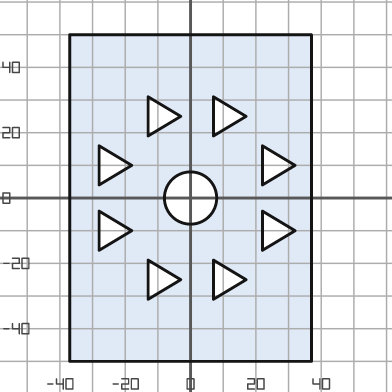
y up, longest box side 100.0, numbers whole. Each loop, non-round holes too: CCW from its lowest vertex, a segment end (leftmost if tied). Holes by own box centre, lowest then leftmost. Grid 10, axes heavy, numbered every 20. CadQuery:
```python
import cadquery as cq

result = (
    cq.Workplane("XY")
    .moveTo(-37.0, -50.0)
    .lineTo(37.0, -50.0)
    .lineTo(37.0, 50.0)
    .lineTo(-37.0, 50.0)
    .close()
    .moveTo(-13.0, -31.0)
    .lineTo(-3.0, -25.0)
    .lineTo(-13.0, -19.0)
    .close()
    .moveTo(7.0, -31.0)
    .lineTo(17.0, -25.0)
    .lineTo(7.0, -19.0)
    .close()
    .moveTo(-28.0, -16.0)
    .lineTo(-18.0, -10.0)
    .lineTo(-28.0, -4.0)
    .close()
    .moveTo(22.0, -16.0)
    .lineTo(32.0, -10.0)
    .lineTo(22.0, -4.0)
    .close()
    .moveTo(0.0, 0.0)
    .circle(8.0)
    .moveTo(-28.0, 4.0)
    .lineTo(-18.0, 10.0)
    .lineTo(-28.0, 16.0)
    .close()
    .moveTo(22.0, 4.0)
    .lineTo(32.0, 10.0)
    .lineTo(22.0, 16.0)
    .close()
    .moveTo(-13.0, 19.0)
    .lineTo(-3.0, 25.0)
    .lineTo(-13.0, 31.0)
    .close()
    .moveTo(7.0, 19.0)
    .lineTo(17.0, 25.0)
    .lineTo(7.0, 31.0)
    .close()
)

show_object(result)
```